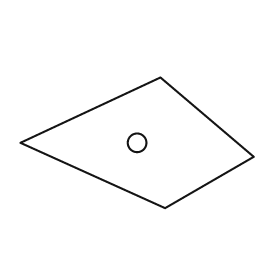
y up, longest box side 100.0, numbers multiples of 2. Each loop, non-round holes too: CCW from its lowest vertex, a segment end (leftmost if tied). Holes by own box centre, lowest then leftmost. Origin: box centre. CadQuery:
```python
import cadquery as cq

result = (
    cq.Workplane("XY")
    .moveTo(12.0, -28.0)
    .lineTo(50.0, -6.0)
    .lineTo(10.0, 28.0)
    .lineTo(-50.0, 0.0)
    .close()
    .moveTo(0.0, 0.0)
    .circle(4.0)
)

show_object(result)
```